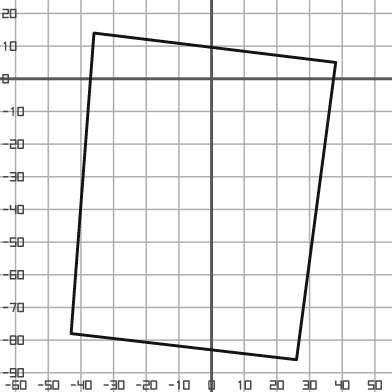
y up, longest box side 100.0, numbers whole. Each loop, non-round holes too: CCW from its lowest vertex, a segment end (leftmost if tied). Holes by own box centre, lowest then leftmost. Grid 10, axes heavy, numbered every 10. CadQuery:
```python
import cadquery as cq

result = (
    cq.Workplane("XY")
    .moveTo(26.0, -86.0)
    .lineTo(38.0, 5.0)
    .lineTo(-36.0, 14.0)
    .lineTo(-43.0, -78.0)
    .close()
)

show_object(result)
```